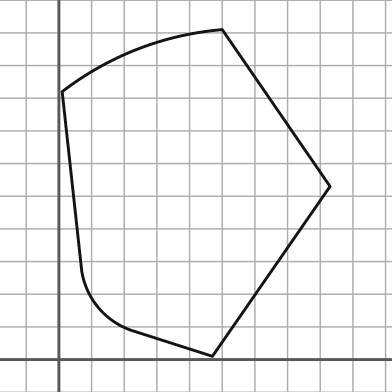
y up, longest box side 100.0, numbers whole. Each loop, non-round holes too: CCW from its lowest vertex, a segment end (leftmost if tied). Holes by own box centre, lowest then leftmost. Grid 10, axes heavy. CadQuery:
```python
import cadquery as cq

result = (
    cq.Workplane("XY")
    .moveTo(47.0, 1.0)
    .lineTo(83.0, 53.0)
    .lineTo(50.0, 101.0)
    .threePointArc((24.0, 95.0), (1.0, 82.0))
    .lineTo(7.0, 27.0)
    .threePointArc((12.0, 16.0), (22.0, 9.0))
    .close()
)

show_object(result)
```